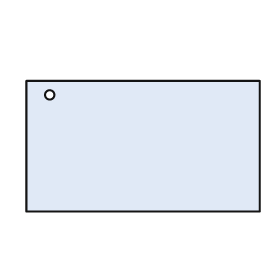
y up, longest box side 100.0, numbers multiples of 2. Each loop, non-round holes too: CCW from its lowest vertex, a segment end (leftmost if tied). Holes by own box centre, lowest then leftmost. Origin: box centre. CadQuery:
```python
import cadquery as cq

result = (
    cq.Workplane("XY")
    .moveTo(-50.0, -28.0)
    .lineTo(50.0, -28.0)
    .lineTo(50.0, 28.0)
    .lineTo(-50.0, 28.0)
    .close()
    .moveTo(-40.0, 22.0)
    .circle(2.0)
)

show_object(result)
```